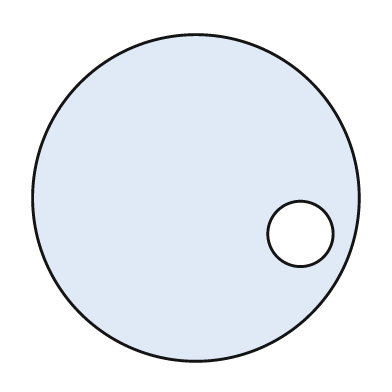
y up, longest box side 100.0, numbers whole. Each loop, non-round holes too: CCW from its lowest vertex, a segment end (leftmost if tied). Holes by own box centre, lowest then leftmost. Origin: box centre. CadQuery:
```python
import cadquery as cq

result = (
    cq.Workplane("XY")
    .moveTo(0.0, 0.0)
    .circle(50.0)
    .moveTo(32.0, -11.0)
    .circle(10.0)
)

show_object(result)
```